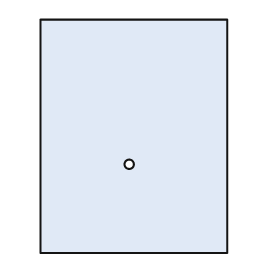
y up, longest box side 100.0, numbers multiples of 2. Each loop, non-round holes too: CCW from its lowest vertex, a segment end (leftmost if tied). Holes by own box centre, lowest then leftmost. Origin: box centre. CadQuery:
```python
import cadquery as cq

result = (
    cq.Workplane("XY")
    .moveTo(-40.0, -50.0)
    .lineTo(40.0, -50.0)
    .lineTo(40.0, 50.0)
    .lineTo(-40.0, 50.0)
    .close()
    .moveTo(-2.0, -12.0)
    .circle(2.0)
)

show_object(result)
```